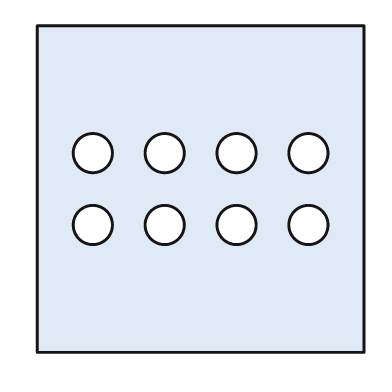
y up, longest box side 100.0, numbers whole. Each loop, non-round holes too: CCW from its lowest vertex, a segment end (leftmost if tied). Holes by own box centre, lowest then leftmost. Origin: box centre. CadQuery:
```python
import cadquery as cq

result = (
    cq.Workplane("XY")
    .moveTo(-50.0, -50.0)
    .lineTo(50.0, -50.0)
    .lineTo(50.0, 50.0)
    .lineTo(-50.0, 50.0)
    .close()
    .moveTo(-33.0, -11.0)
    .circle(6.0)
    .moveTo(-11.0, -11.0)
    .circle(6.0)
    .moveTo(11.0, -11.0)
    .circle(6.0)
    .moveTo(33.0, -11.0)
    .circle(6.0)
    .moveTo(-33.0, 11.0)
    .circle(6.0)
    .moveTo(-11.0, 11.0)
    .circle(6.0)
    .moveTo(11.0, 11.0)
    .circle(6.0)
    .moveTo(33.0, 11.0)
    .circle(6.0)
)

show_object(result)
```